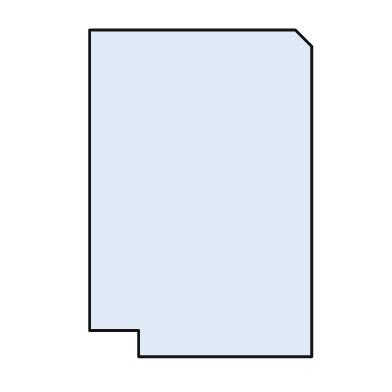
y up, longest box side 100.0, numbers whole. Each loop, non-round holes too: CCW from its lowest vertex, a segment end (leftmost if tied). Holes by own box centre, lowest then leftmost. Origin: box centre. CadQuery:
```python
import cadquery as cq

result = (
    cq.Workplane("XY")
    .moveTo(-19.0, -50.0)
    .lineTo(34.0, -50.0)
    .lineTo(34.0, 45.0)
    .lineTo(29.0, 50.0)
    .lineTo(-34.0, 50.0)
    .lineTo(-34.0, -42.0)
    .lineTo(-19.0, -42.0)
    .close()
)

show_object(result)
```